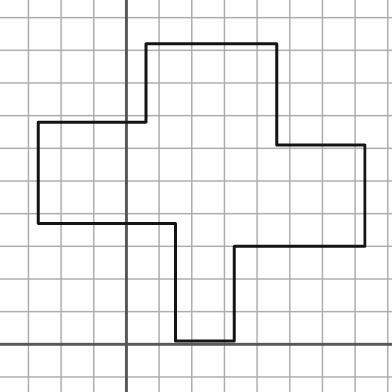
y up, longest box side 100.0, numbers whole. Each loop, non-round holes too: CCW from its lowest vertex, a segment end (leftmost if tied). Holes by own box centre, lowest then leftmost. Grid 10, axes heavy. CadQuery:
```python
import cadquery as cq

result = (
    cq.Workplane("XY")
    .moveTo(15.0, 1.0)
    .lineTo(33.0, 1.0)
    .lineTo(33.0, 30.0)
    .lineTo(73.0, 30.0)
    .lineTo(73.0, 61.0)
    .lineTo(46.0, 61.0)
    .lineTo(46.0, 92.0)
    .lineTo(6.0, 92.0)
    .lineTo(6.0, 68.0)
    .lineTo(-27.0, 68.0)
    .lineTo(-27.0, 37.0)
    .lineTo(15.0, 37.0)
    .close()
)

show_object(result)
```